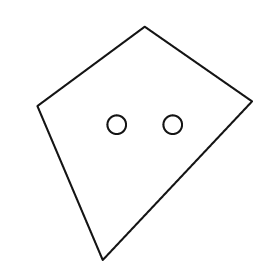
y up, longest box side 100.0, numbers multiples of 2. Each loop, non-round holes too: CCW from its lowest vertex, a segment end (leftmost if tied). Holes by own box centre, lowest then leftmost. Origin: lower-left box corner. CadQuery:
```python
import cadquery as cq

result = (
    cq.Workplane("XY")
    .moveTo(28.0, 0.0)
    .lineTo(92.0, 68.0)
    .lineTo(46.0, 100.0)
    .lineTo(0.0, 66.0)
    .close()
    .moveTo(34.0, 58.0)
    .circle(4.0)
    .moveTo(58.0, 58.0)
    .circle(4.0)
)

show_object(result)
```